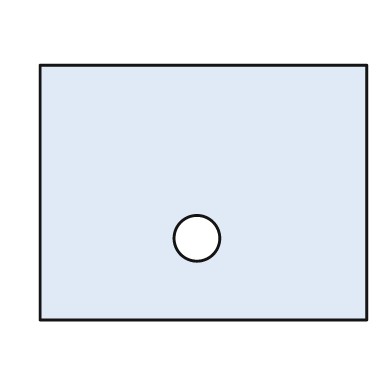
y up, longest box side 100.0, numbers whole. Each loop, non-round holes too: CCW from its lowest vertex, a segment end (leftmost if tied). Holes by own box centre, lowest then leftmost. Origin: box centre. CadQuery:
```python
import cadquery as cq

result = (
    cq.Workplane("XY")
    .moveTo(-50.0, -39.0)
    .lineTo(50.0, -39.0)
    .lineTo(50.0, 39.0)
    .lineTo(-50.0, 39.0)
    .close()
    .moveTo(-2.0, -14.0)
    .circle(7.0)
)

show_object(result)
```